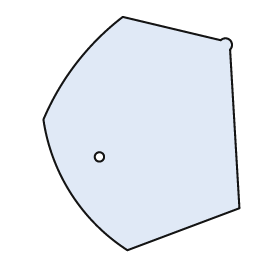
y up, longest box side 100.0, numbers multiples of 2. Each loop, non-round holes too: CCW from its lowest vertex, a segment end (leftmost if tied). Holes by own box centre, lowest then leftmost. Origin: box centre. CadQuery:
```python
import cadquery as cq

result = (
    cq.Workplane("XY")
    .moveTo(-6.0, -50.0)
    .lineTo(42.0, -32.0)
    .lineTo(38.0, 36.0)
    .threePointArc((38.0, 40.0), (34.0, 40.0))
    .lineTo(-8.0, 50.0)
    .threePointArc((-28.0, 30.0), (-42.0, 6.0))
    .threePointArc((-30.0, -26.0), (-6.0, -50.0))
    .close()
    .moveTo(-18.0, -10.0)
    .circle(2.0)
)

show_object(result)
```